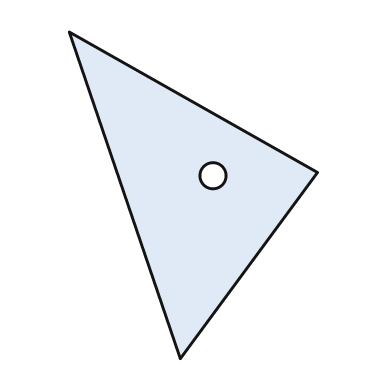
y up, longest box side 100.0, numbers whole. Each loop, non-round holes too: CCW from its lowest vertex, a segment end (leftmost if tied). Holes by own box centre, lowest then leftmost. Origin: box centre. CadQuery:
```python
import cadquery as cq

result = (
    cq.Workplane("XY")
    .moveTo(-4.0, -50.0)
    .lineTo(38.0, 7.0)
    .lineTo(-38.0, 50.0)
    .close()
    .moveTo(6.0, 6.0)
    .circle(4.0)
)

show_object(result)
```